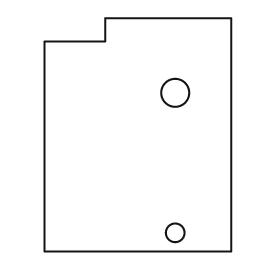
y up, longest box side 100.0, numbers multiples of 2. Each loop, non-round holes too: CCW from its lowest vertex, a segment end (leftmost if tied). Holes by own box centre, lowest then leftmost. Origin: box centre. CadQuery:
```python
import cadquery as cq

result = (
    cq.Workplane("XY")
    .moveTo(-40.0, -50.0)
    .lineTo(40.0, -50.0)
    .lineTo(40.0, 50.0)
    .lineTo(-14.0, 50.0)
    .lineTo(-14.0, 40.0)
    .lineTo(-40.0, 40.0)
    .close()
    .moveTo(16.0, -42.0)
    .circle(4.0)
    .moveTo(16.0, 18.0)
    .circle(6.0)
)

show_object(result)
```